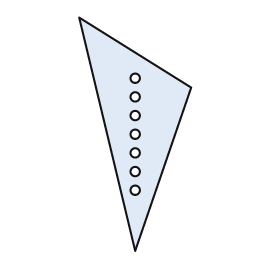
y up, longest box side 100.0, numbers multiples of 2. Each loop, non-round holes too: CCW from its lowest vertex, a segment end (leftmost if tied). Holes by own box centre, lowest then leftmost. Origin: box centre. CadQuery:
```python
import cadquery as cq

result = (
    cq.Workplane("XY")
    .moveTo(0.0, -50.0)
    .lineTo(24.0, 20.0)
    .lineTo(-24.0, 50.0)
    .close()
    .moveTo(0.0, -24.0)
    .circle(2.0)
    .moveTo(0.0, -16.0)
    .circle(2.0)
    .moveTo(0.0, -8.0)
    .circle(2.0)
    .moveTo(0.0, 0.0)
    .circle(2.0)
    .moveTo(0.0, 8.0)
    .circle(2.0)
    .moveTo(0.0, 16.0)
    .circle(2.0)
    .moveTo(0.0, 24.0)
    .circle(2.0)
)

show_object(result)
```